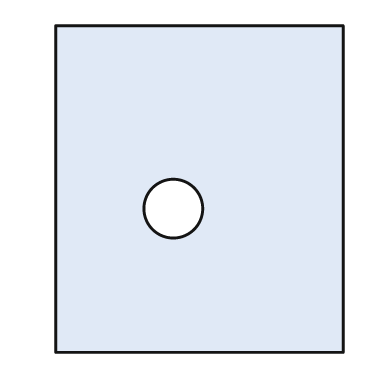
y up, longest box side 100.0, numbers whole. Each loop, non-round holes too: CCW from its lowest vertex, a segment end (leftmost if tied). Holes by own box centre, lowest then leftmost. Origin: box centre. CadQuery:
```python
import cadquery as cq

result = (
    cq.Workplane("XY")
    .moveTo(-44.0, -50.0)
    .lineTo(44.0, -50.0)
    .lineTo(44.0, 50.0)
    .lineTo(-44.0, 50.0)
    .close()
    .moveTo(-8.0, -6.0)
    .circle(9.0)
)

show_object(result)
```